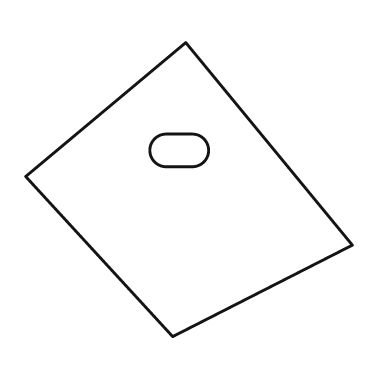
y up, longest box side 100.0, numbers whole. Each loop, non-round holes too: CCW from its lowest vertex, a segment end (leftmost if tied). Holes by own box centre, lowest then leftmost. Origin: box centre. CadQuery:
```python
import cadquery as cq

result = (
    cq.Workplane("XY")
    .moveTo(-5.0, -45.0)
    .lineTo(50.0, -17.0)
    .lineTo(-1.0, 45.0)
    .lineTo(-50.0, 4.0)
    .close()
    .moveTo(-7.0, 7.0)
    .lineTo(1.0, 7.0)
    .threePointArc((6.0, 12.0), (1.0, 17.0))
    .lineTo(-7.0, 17.0)
    .threePointArc((-12.0, 12.0), (-7.0, 7.0))
    .close()
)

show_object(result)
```